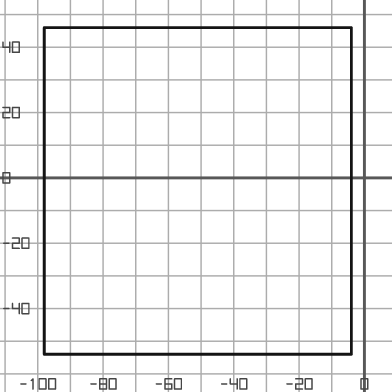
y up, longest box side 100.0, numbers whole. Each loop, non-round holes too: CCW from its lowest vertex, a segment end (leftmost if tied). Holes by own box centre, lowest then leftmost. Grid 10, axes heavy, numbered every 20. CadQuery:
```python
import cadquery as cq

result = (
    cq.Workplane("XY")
    .moveTo(-98.0, -54.0)
    .lineTo(-4.0, -54.0)
    .lineTo(-4.0, 46.0)
    .lineTo(-98.0, 46.0)
    .close()
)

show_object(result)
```